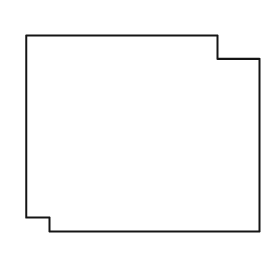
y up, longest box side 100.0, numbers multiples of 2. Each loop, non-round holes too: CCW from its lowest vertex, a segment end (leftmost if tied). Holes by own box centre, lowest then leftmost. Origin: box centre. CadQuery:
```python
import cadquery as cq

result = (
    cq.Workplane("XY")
    .moveTo(-40.0, -42.0)
    .lineTo(50.0, -42.0)
    .lineTo(50.0, 32.0)
    .lineTo(32.0, 32.0)
    .lineTo(32.0, 42.0)
    .lineTo(-50.0, 42.0)
    .lineTo(-50.0, -36.0)
    .lineTo(-40.0, -36.0)
    .close()
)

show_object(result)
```